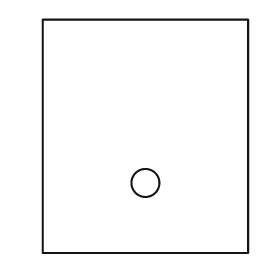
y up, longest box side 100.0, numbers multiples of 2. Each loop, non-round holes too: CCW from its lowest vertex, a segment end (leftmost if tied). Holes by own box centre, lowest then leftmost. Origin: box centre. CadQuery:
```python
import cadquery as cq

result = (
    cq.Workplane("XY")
    .moveTo(-44.0, -50.0)
    .lineTo(44.0, -50.0)
    .lineTo(44.0, 50.0)
    .lineTo(-44.0, 50.0)
    .close()
    .moveTo(0.0, -20.0)
    .circle(6.0)
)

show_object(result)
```